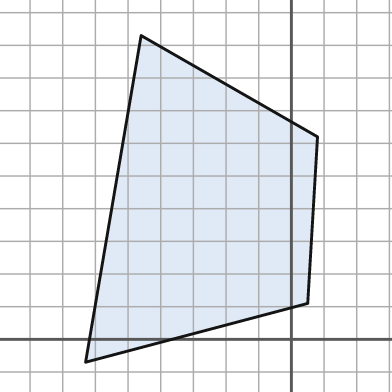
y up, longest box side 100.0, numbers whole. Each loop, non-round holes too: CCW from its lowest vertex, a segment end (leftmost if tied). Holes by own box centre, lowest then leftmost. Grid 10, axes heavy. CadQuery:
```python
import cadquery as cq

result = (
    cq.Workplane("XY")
    .moveTo(-63.0, -7.0)
    .lineTo(5.0, 11.0)
    .lineTo(8.0, 62.0)
    .lineTo(-46.0, 93.0)
    .close()
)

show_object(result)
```